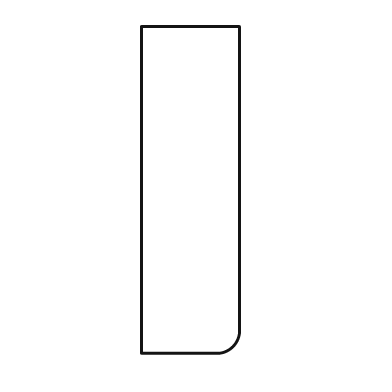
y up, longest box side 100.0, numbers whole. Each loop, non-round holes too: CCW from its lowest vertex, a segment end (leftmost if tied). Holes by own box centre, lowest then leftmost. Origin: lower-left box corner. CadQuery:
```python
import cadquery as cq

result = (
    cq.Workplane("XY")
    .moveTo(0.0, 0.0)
    .lineTo(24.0, 0.0)
    .threePointArc((28.0, 2.0), (30.0, 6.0))
    .lineTo(30.0, 100.0)
    .lineTo(0.0, 100.0)
    .close()
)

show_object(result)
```